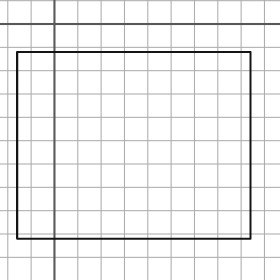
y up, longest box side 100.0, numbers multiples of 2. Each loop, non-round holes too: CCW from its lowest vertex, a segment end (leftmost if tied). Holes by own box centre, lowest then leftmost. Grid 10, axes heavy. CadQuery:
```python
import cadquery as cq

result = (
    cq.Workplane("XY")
    .moveTo(-16.0, -92.0)
    .lineTo(84.0, -92.0)
    .lineTo(84.0, -12.0)
    .lineTo(-16.0, -12.0)
    .close()
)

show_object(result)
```